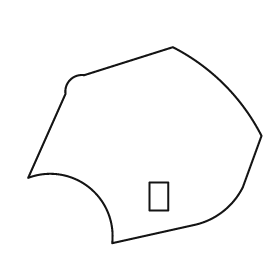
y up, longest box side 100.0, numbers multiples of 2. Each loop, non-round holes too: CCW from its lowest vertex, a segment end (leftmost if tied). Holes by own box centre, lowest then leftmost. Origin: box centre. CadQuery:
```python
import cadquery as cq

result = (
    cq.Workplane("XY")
    .moveTo(-14.0, -42.0)
    .lineTo(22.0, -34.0)
    .threePointArc((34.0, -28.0), (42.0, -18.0))
    .lineTo(50.0, 4.0)
    .threePointArc((34.0, 26.0), (12.0, 42.0))
    .lineTo(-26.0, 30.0)
    .threePointArc((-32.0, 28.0), (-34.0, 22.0))
    .lineTo(-50.0, -14.0)
    .threePointArc((-24.0, -18.0), (-14.0, -42.0))
    .close()
    .moveTo(2.0, -28.0)
    .lineTo(10.0, -28.0)
    .lineTo(10.0, -16.0)
    .lineTo(2.0, -16.0)
    .close()
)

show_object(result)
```